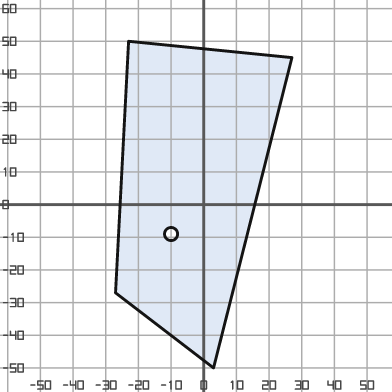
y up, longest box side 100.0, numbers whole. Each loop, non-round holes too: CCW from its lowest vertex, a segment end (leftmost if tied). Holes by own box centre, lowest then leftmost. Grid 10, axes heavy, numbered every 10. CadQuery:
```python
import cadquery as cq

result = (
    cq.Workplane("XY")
    .moveTo(3.0, -50.0)
    .lineTo(27.0, 45.0)
    .lineTo(-23.0, 50.0)
    .lineTo(-27.0, -27.0)
    .close()
    .moveTo(-10.0, -9.0)
    .circle(2.0)
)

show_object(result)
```